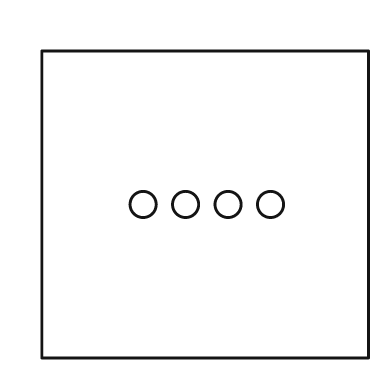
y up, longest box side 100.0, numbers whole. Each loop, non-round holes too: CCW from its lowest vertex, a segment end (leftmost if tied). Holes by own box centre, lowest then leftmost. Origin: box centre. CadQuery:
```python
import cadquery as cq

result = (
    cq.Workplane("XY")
    .moveTo(-50.0, -47.0)
    .lineTo(50.0, -47.0)
    .lineTo(50.0, 47.0)
    .lineTo(-50.0, 47.0)
    .close()
    .moveTo(-19.0, 0.0)
    .circle(4.0)
    .moveTo(-6.0, 0.0)
    .circle(4.0)
    .moveTo(7.0, 0.0)
    .circle(4.0)
    .moveTo(20.0, 0.0)
    .circle(4.0)
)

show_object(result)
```